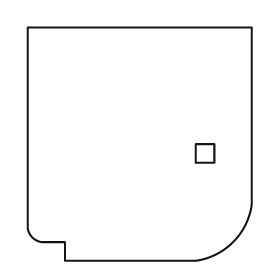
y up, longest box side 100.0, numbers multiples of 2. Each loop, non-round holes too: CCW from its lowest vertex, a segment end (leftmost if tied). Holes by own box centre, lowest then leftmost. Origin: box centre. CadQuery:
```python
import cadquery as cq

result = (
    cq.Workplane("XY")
    .moveTo(-32.0, -50.0)
    .lineTo(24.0, -50.0)
    .threePointArc((40.0, -42.0), (48.0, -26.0))
    .lineTo(48.0, 50.0)
    .lineTo(-48.0, 50.0)
    .lineTo(-48.0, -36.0)
    .threePointArc((-46.0, -40.0), (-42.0, -42.0))
    .lineTo(-32.0, -42.0)
    .close()
    .moveTo(24.0, -8.0)
    .lineTo(32.0, -8.0)
    .lineTo(32.0, 0.0)
    .lineTo(24.0, 0.0)
    .close()
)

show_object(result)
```